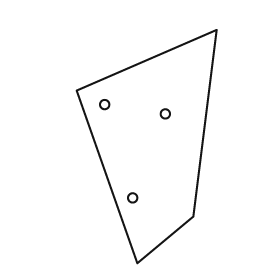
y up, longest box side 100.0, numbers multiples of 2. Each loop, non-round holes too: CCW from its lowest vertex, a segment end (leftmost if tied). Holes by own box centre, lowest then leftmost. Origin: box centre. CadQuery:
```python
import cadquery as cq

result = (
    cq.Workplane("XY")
    .moveTo(-4.0, -50.0)
    .lineTo(20.0, -30.0)
    .lineTo(30.0, 50.0)
    .lineTo(-30.0, 24.0)
    .close()
    .moveTo(-6.0, -22.0)
    .circle(2.0)
    .moveTo(8.0, 14.0)
    .circle(2.0)
    .moveTo(-18.0, 18.0)
    .circle(2.0)
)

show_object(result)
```